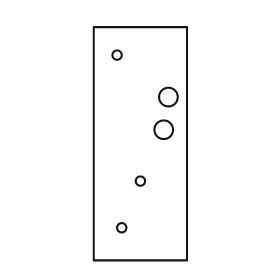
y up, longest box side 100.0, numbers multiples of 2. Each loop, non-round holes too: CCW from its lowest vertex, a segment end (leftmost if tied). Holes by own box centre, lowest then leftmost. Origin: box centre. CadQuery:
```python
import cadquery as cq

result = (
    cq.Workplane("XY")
    .moveTo(-20.0, -50.0)
    .lineTo(20.0, -50.0)
    .lineTo(20.0, 50.0)
    .lineTo(-20.0, 50.0)
    .close()
    .moveTo(-8.0, -36.0)
    .circle(2.0)
    .moveTo(0.0, -16.0)
    .circle(2.0)
    .moveTo(10.0, 6.0)
    .circle(4.0)
    .moveTo(12.0, 20.0)
    .circle(4.0)
    .moveTo(-10.0, 38.0)
    .circle(2.0)
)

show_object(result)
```